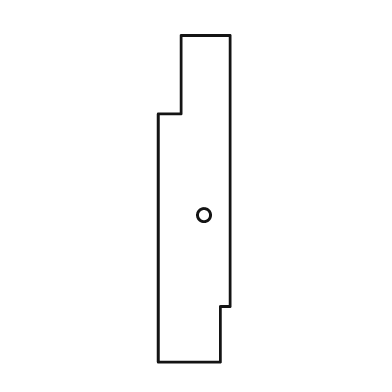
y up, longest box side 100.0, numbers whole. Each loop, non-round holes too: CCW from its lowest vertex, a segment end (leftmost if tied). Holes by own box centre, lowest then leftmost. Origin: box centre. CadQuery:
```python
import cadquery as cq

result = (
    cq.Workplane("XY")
    .moveTo(-11.0, -50.0)
    .lineTo(8.0, -50.0)
    .lineTo(8.0, -33.0)
    .lineTo(11.0, -33.0)
    .lineTo(11.0, 50.0)
    .lineTo(-4.0, 50.0)
    .lineTo(-4.0, 26.0)
    .lineTo(-11.0, 26.0)
    .close()
    .moveTo(3.0, -5.0)
    .circle(2.0)
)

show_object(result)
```